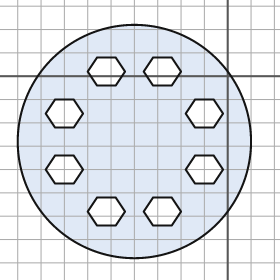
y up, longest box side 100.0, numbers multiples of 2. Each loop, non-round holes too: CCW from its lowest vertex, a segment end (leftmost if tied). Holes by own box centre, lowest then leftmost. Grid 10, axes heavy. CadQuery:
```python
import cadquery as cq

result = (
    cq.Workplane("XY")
    .moveTo(-40.0, -28.0)
    .circle(50.0)
    .moveTo(-56.0, -64.0)
    .lineTo(-48.0, -64.0)
    .lineTo(-44.0, -58.0)
    .lineTo(-48.0, -52.0)
    .lineTo(-56.0, -52.0)
    .lineTo(-60.0, -58.0)
    .close()
    .moveTo(-32.0, -64.0)
    .lineTo(-24.0, -64.0)
    .lineTo(-20.0, -58.0)
    .lineTo(-24.0, -52.0)
    .lineTo(-32.0, -52.0)
    .lineTo(-36.0, -58.0)
    .close()
    .moveTo(-74.0, -46.0)
    .lineTo(-66.0, -46.0)
    .lineTo(-62.0, -40.0)
    .lineTo(-66.0, -34.0)
    .lineTo(-74.0, -34.0)
    .lineTo(-78.0, -40.0)
    .close()
    .moveTo(-14.0, -46.0)
    .lineTo(-6.0, -46.0)
    .lineTo(-2.0, -40.0)
    .lineTo(-6.0, -34.0)
    .lineTo(-14.0, -34.0)
    .lineTo(-18.0, -40.0)
    .close()
    .moveTo(-74.0, -22.0)
    .lineTo(-66.0, -22.0)
    .lineTo(-62.0, -16.0)
    .lineTo(-66.0, -10.0)
    .lineTo(-74.0, -10.0)
    .lineTo(-78.0, -16.0)
    .close()
    .moveTo(-14.0, -22.0)
    .lineTo(-6.0, -22.0)
    .lineTo(-2.0, -16.0)
    .lineTo(-6.0, -10.0)
    .lineTo(-14.0, -10.0)
    .lineTo(-18.0, -16.0)
    .close()
    .moveTo(-56.0, -4.0)
    .lineTo(-48.0, -4.0)
    .lineTo(-44.0, 2.0)
    .lineTo(-48.0, 8.0)
    .lineTo(-56.0, 8.0)
    .lineTo(-60.0, 2.0)
    .close()
    .moveTo(-32.0, -4.0)
    .lineTo(-24.0, -4.0)
    .lineTo(-20.0, 2.0)
    .lineTo(-24.0, 8.0)
    .lineTo(-32.0, 8.0)
    .lineTo(-36.0, 2.0)
    .close()
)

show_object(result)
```